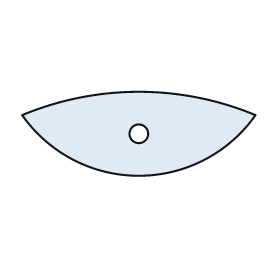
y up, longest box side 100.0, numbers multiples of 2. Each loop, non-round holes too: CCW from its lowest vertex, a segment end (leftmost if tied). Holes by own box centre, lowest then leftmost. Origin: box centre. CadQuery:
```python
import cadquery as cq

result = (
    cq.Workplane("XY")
    .moveTo(-50.0, 8.0)
    .threePointArc((0.0, -18.0), (50.0, 8.0))
    .threePointArc((0.0, 18.0), (-50.0, 8.0))
    .close()
    .moveTo(0.0, 0.0)
    .circle(4.0)
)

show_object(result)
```